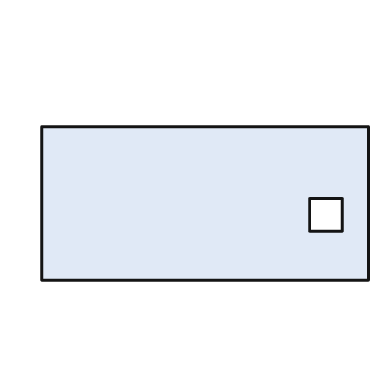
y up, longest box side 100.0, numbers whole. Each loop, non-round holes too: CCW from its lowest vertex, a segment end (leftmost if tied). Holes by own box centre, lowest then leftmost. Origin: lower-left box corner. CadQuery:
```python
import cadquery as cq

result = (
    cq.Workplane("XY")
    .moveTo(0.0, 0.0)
    .lineTo(100.0, 0.0)
    .lineTo(100.0, 47.0)
    .lineTo(0.0, 47.0)
    .close()
    .moveTo(82.0, 15.0)
    .lineTo(92.0, 15.0)
    .lineTo(92.0, 25.0)
    .lineTo(82.0, 25.0)
    .close()
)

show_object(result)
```